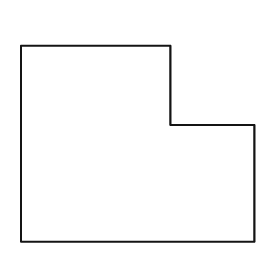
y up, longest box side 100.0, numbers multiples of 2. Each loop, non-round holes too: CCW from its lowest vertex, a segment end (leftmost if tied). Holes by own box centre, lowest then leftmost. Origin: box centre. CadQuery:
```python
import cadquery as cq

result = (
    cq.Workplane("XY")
    .moveTo(-50.0, -42.0)
    .lineTo(50.0, -42.0)
    .lineTo(50.0, 8.0)
    .lineTo(14.0, 8.0)
    .lineTo(14.0, 42.0)
    .lineTo(-50.0, 42.0)
    .close()
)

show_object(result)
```